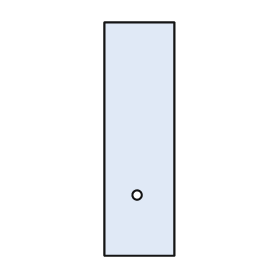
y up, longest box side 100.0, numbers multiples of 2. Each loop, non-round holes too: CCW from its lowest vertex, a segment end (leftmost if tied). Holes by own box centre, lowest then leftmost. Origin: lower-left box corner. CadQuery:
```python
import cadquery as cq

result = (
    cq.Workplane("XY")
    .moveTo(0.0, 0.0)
    .lineTo(30.0, 0.0)
    .lineTo(30.0, 100.0)
    .lineTo(0.0, 100.0)
    .close()
    .moveTo(14.0, 26.0)
    .circle(2.0)
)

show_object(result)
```